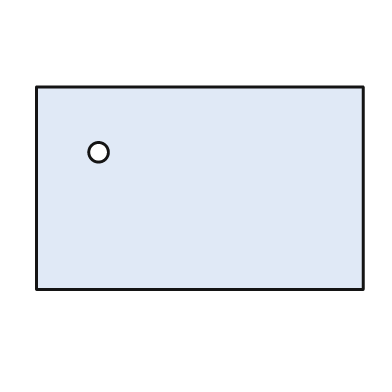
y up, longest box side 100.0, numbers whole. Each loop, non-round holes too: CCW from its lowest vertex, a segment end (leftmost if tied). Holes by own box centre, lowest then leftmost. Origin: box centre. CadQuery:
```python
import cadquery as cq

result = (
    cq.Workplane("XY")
    .moveTo(-50.0, -31.0)
    .lineTo(50.0, -31.0)
    .lineTo(50.0, 31.0)
    .lineTo(-50.0, 31.0)
    .close()
    .moveTo(-31.0, 11.0)
    .circle(3.0)
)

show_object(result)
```